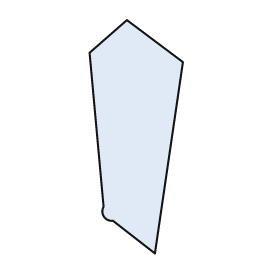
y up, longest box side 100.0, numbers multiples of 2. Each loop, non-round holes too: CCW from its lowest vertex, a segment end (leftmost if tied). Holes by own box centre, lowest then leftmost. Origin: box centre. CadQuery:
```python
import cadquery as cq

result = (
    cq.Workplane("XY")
    .moveTo(8.0, -50.0)
    .lineTo(20.0, 32.0)
    .lineTo(-4.0, 50.0)
    .lineTo(-20.0, 36.0)
    .lineTo(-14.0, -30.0)
    .threePointArc((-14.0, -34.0), (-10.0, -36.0))
    .close()
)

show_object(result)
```